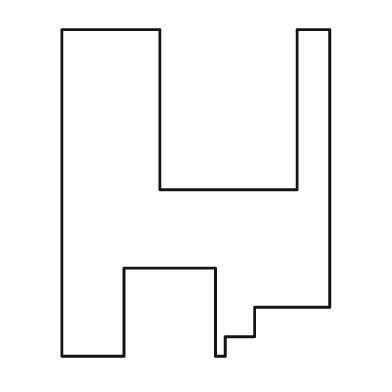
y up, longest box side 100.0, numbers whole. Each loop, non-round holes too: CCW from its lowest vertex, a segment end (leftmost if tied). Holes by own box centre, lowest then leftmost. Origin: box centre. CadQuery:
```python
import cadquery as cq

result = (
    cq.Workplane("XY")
    .moveTo(-41.0, -50.0)
    .lineTo(-22.0, -50.0)
    .lineTo(-22.0, -23.0)
    .lineTo(6.0, -23.0)
    .lineTo(6.0, -50.0)
    .lineTo(9.0, -50.0)
    .lineTo(9.0, -44.0)
    .lineTo(18.0, -44.0)
    .lineTo(18.0, -35.0)
    .lineTo(41.0, -35.0)
    .lineTo(41.0, 50.0)
    .lineTo(31.0, 50.0)
    .lineTo(31.0, 1.0)
    .lineTo(-11.0, 1.0)
    .lineTo(-11.0, 50.0)
    .lineTo(-41.0, 50.0)
    .close()
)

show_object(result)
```